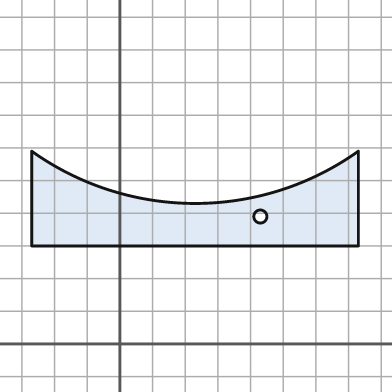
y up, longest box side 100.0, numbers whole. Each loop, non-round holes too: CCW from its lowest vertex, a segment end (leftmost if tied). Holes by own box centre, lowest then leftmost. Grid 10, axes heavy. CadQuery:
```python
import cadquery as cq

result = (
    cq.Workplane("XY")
    .moveTo(-27.0, 30.0)
    .lineTo(73.0, 30.0)
    .lineTo(73.0, 59.0)
    .threePointArc((23.0, 43.0), (-27.0, 59.0))
    .close()
    .moveTo(43.0, 39.0)
    .circle(2.0)
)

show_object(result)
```